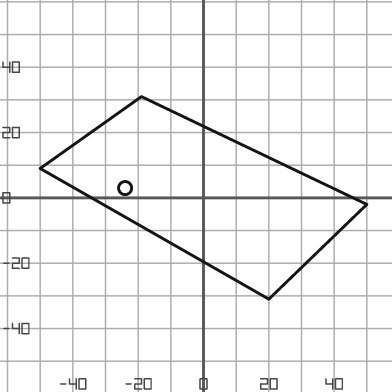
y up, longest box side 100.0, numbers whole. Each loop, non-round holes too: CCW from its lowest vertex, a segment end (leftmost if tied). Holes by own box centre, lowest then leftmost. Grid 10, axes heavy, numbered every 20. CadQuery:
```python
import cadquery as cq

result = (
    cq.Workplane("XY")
    .moveTo(20.0, -31.0)
    .lineTo(50.0, -2.0)
    .lineTo(-19.0, 31.0)
    .lineTo(-50.0, 9.0)
    .close()
    .moveTo(-24.0, 3.0)
    .circle(2.0)
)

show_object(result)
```